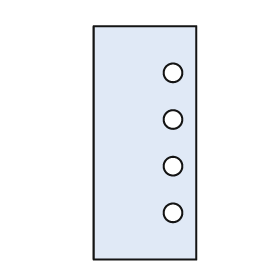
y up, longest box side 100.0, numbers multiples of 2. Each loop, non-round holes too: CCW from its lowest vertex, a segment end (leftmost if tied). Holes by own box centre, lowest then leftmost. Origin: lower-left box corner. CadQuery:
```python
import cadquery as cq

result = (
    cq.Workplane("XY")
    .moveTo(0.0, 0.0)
    .lineTo(44.0, 0.0)
    .lineTo(44.0, 100.0)
    .lineTo(0.0, 100.0)
    .close()
    .moveTo(34.0, 20.0)
    .circle(4.0)
    .moveTo(34.0, 40.0)
    .circle(4.0)
    .moveTo(34.0, 60.0)
    .circle(4.0)
    .moveTo(34.0, 80.0)
    .circle(4.0)
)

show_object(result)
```